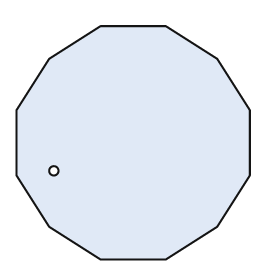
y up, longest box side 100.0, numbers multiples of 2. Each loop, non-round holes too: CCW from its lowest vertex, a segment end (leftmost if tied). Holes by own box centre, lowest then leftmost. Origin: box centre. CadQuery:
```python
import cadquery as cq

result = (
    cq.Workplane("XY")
    .moveTo(-14.0, -50.0)
    .lineTo(14.0, -50.0)
    .lineTo(36.0, -36.0)
    .lineTo(50.0, -14.0)
    .lineTo(50.0, 14.0)
    .lineTo(36.0, 36.0)
    .lineTo(14.0, 50.0)
    .lineTo(-14.0, 50.0)
    .lineTo(-36.0, 36.0)
    .lineTo(-50.0, 14.0)
    .lineTo(-50.0, -14.0)
    .lineTo(-36.0, -36.0)
    .close()
    .moveTo(-34.0, -12.0)
    .circle(2.0)
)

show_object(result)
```